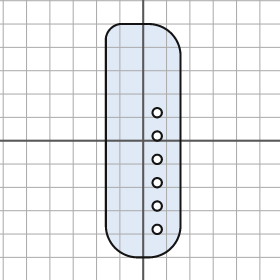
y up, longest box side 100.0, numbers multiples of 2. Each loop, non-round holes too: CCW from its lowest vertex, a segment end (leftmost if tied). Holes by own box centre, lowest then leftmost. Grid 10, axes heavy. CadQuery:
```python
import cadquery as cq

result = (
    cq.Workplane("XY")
    .moveTo(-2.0, -50.0)
    .lineTo(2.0, -50.0)
    .threePointArc((12.0, -46.0), (16.0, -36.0))
    .lineTo(16.0, 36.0)
    .threePointArc((12.0, 46.0), (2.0, 50.0))
    .lineTo(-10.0, 50.0)
    .threePointArc((-14.0, 48.0), (-16.0, 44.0))
    .lineTo(-16.0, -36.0)
    .threePointArc((-12.0, -46.0), (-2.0, -50.0))
    .close()
    .moveTo(6.0, -38.0)
    .circle(2.0)
    .moveTo(6.0, -28.0)
    .circle(2.0)
    .moveTo(6.0, -18.0)
    .circle(2.0)
    .moveTo(6.0, -8.0)
    .circle(2.0)
    .moveTo(6.0, 2.0)
    .circle(2.0)
    .moveTo(6.0, 12.0)
    .circle(2.0)
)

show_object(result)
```